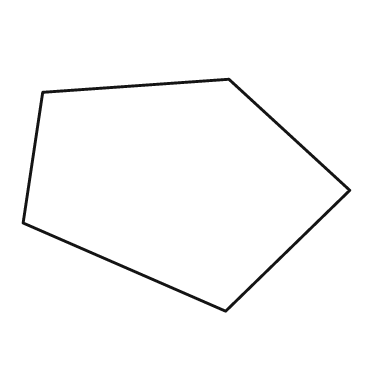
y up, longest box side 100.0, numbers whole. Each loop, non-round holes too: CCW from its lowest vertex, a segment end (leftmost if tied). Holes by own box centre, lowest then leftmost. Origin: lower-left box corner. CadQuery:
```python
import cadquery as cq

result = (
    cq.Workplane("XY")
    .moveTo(62.0, 0.0)
    .lineTo(100.0, 37.0)
    .lineTo(63.0, 71.0)
    .lineTo(6.0, 67.0)
    .lineTo(0.0, 27.0)
    .close()
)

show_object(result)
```